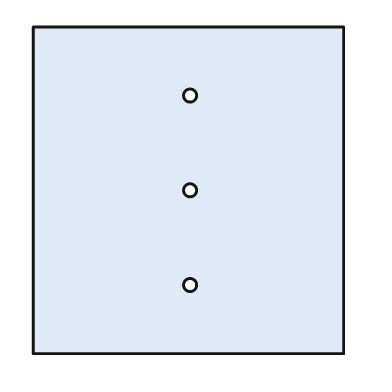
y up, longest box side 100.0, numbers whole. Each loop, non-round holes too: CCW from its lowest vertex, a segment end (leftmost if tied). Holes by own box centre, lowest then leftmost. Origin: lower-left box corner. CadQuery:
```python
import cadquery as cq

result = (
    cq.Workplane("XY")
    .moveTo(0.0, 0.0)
    .lineTo(95.0, 0.0)
    .lineTo(95.0, 100.0)
    .lineTo(0.0, 100.0)
    .close()
    .moveTo(48.0, 21.0)
    .circle(2.0)
    .moveTo(48.0, 50.0)
    .circle(2.0)
    .moveTo(48.0, 79.0)
    .circle(2.0)
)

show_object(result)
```